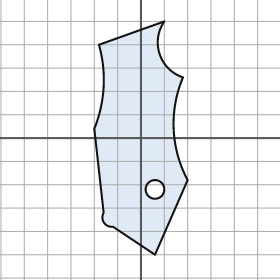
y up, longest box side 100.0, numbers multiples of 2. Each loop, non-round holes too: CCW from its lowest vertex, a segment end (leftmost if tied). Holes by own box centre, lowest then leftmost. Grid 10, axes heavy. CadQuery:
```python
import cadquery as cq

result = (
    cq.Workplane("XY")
    .moveTo(6.0, -50.0)
    .lineTo(20.0, -18.0)
    .threePointArc((14.0, 4.0), (18.0, 26.0))
    .threePointArc((8.0, 36.0), (10.0, 50.0))
    .lineTo(-18.0, 40.0)
    .threePointArc((-16.0, 22.0), (-20.0, 4.0))
    .lineTo(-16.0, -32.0)
    .threePointArc((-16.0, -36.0), (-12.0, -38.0))
    .close()
    .moveTo(6.0, -22.0)
    .circle(4.0)
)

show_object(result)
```